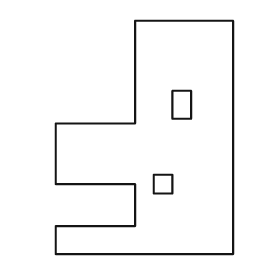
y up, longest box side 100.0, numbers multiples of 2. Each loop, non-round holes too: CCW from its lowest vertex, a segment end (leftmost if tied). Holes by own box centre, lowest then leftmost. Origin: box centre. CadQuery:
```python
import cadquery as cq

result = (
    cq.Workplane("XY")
    .moveTo(-38.0, -50.0)
    .lineTo(38.0, -50.0)
    .lineTo(38.0, 50.0)
    .lineTo(-4.0, 50.0)
    .lineTo(-4.0, 6.0)
    .lineTo(-38.0, 6.0)
    .lineTo(-38.0, -20.0)
    .lineTo(-4.0, -20.0)
    .lineTo(-4.0, -38.0)
    .lineTo(-38.0, -38.0)
    .close()
    .moveTo(4.0, -24.0)
    .lineTo(12.0, -24.0)
    .lineTo(12.0, -16.0)
    .lineTo(4.0, -16.0)
    .close()
    .moveTo(12.0, 8.0)
    .lineTo(20.0, 8.0)
    .lineTo(20.0, 20.0)
    .lineTo(12.0, 20.0)
    .close()
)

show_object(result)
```